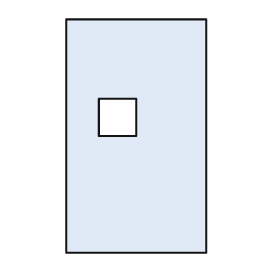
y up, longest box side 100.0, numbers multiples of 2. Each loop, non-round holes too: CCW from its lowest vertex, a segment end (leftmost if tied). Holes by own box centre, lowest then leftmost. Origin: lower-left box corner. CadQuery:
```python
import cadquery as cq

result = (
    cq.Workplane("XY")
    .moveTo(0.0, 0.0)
    .lineTo(60.0, 0.0)
    .lineTo(60.0, 100.0)
    .lineTo(0.0, 100.0)
    .close()
    .moveTo(14.0, 50.0)
    .lineTo(30.0, 50.0)
    .lineTo(30.0, 66.0)
    .lineTo(14.0, 66.0)
    .close()
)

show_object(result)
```